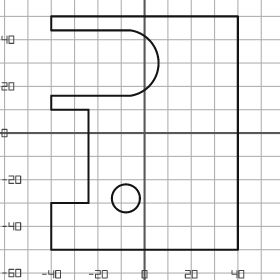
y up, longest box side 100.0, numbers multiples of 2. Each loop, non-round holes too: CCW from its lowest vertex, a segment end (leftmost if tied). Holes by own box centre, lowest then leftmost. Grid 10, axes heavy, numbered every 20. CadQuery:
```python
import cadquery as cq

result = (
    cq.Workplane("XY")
    .moveTo(-40.0, -50.0)
    .lineTo(40.0, -50.0)
    .lineTo(40.0, 50.0)
    .lineTo(-40.0, 50.0)
    .lineTo(-40.0, 44.0)
    .lineTo(-6.0, 44.0)
    .threePointArc((6.0, 30.0), (-6.0, 16.0))
    .lineTo(-40.0, 16.0)
    .lineTo(-40.0, 10.0)
    .lineTo(-24.0, 10.0)
    .lineTo(-24.0, -30.0)
    .lineTo(-40.0, -30.0)
    .close()
    .moveTo(-8.0, -28.0)
    .circle(6.0)
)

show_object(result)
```